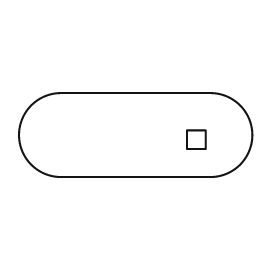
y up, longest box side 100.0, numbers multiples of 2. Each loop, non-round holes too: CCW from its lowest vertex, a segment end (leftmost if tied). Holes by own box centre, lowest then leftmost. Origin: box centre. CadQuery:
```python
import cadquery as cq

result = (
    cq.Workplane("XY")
    .moveTo(-32.0, -18.0)
    .lineTo(32.0, -18.0)
    .threePointArc((50.0, 0.0), (32.0, 18.0))
    .lineTo(-32.0, 18.0)
    .threePointArc((-50.0, 0.0), (-32.0, -18.0))
    .close()
    .moveTo(22.0, -6.0)
    .lineTo(30.0, -6.0)
    .lineTo(30.0, 2.0)
    .lineTo(22.0, 2.0)
    .close()
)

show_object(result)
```